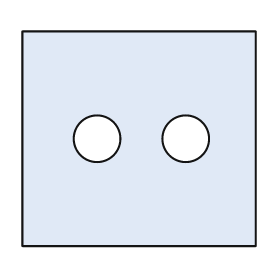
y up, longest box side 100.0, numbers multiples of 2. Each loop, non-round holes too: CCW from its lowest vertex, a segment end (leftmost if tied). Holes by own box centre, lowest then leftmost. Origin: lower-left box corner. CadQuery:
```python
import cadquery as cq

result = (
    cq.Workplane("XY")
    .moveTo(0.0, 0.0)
    .lineTo(100.0, 0.0)
    .lineTo(100.0, 92.0)
    .lineTo(0.0, 92.0)
    .close()
    .moveTo(32.0, 46.0)
    .circle(10.0)
    .moveTo(70.0, 46.0)
    .circle(10.0)
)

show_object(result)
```